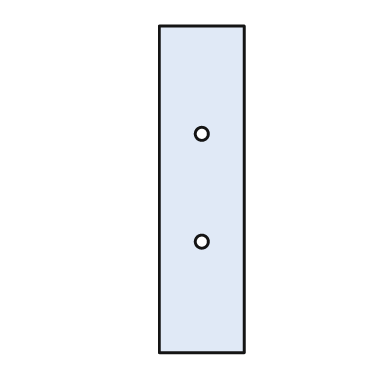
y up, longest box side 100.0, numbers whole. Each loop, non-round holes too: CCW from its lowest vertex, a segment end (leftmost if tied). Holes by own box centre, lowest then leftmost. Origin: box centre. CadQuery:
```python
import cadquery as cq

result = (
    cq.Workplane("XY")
    .moveTo(-13.0, -50.0)
    .lineTo(13.0, -50.0)
    .lineTo(13.0, 50.0)
    .lineTo(-13.0, 50.0)
    .close()
    .moveTo(0.0, -16.0)
    .circle(2.0)
    .moveTo(0.0, 17.0)
    .circle(2.0)
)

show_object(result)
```